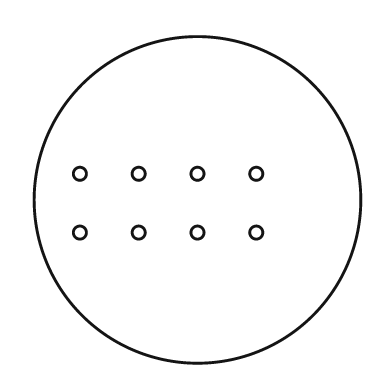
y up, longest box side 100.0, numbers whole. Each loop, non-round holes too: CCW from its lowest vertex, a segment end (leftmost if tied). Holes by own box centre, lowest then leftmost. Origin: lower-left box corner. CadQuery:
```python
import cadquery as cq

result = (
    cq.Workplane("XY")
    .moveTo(50.0, 50.0)
    .circle(50.0)
    .moveTo(14.0, 40.0)
    .circle(2.0)
    .moveTo(32.0, 40.0)
    .circle(2.0)
    .moveTo(50.0, 40.0)
    .circle(2.0)
    .moveTo(68.0, 40.0)
    .circle(2.0)
    .moveTo(14.0, 58.0)
    .circle(2.0)
    .moveTo(32.0, 58.0)
    .circle(2.0)
    .moveTo(50.0, 58.0)
    .circle(2.0)
    .moveTo(68.0, 58.0)
    .circle(2.0)
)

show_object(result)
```